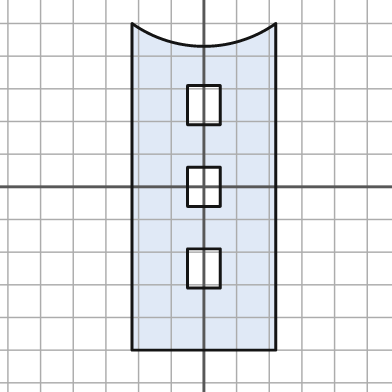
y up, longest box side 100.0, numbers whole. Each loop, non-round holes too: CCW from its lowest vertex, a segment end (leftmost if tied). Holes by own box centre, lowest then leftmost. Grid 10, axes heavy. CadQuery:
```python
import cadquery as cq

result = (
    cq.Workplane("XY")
    .moveTo(-22.0, -50.0)
    .lineTo(22.0, -50.0)
    .lineTo(22.0, 50.0)
    .threePointArc((0.0, 43.0), (-22.0, 50.0))
    .close()
    .moveTo(-5.0, -31.0)
    .lineTo(5.0, -31.0)
    .lineTo(5.0, -19.0)
    .lineTo(-5.0, -19.0)
    .close()
    .moveTo(-5.0, -6.0)
    .lineTo(5.0, -6.0)
    .lineTo(5.0, 6.0)
    .lineTo(-5.0, 6.0)
    .close()
    .moveTo(-5.0, 19.0)
    .lineTo(5.0, 19.0)
    .lineTo(5.0, 31.0)
    .lineTo(-5.0, 31.0)
    .close()
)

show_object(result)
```